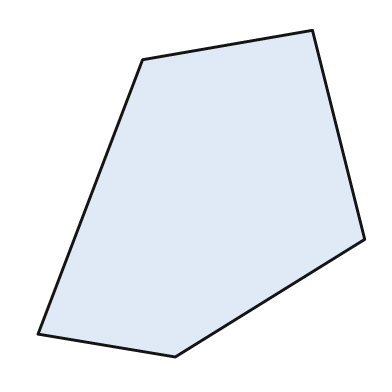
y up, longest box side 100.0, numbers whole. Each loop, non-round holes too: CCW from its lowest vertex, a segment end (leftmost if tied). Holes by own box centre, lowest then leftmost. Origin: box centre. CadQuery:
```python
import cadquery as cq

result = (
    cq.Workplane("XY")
    .moveTo(-8.0, -50.0)
    .lineTo(50.0, -14.0)
    .lineTo(34.0, 50.0)
    .lineTo(-18.0, 41.0)
    .lineTo(-50.0, -43.0)
    .close()
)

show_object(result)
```